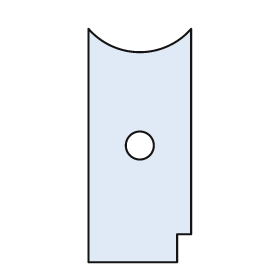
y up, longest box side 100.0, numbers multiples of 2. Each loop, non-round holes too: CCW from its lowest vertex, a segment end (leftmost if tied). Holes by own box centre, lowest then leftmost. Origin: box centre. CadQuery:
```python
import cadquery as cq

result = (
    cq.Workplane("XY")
    .moveTo(-22.0, -50.0)
    .lineTo(16.0, -50.0)
    .lineTo(16.0, -38.0)
    .lineTo(22.0, -38.0)
    .lineTo(22.0, 50.0)
    .threePointArc((0.0, 40.0), (-22.0, 50.0))
    .close()
    .moveTo(0.0, 0.0)
    .circle(6.0)
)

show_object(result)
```